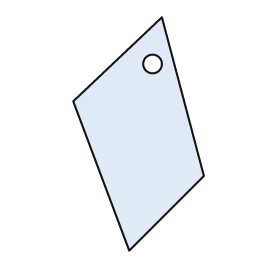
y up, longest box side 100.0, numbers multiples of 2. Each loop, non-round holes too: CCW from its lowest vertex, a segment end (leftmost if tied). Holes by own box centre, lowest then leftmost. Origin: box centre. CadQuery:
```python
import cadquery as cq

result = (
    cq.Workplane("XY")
    .moveTo(-4.0, -50.0)
    .lineTo(28.0, -18.0)
    .lineTo(10.0, 50.0)
    .lineTo(-28.0, 14.0)
    .close()
    .moveTo(6.0, 30.0)
    .circle(4.0)
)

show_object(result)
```